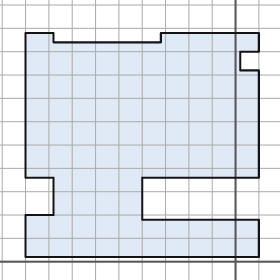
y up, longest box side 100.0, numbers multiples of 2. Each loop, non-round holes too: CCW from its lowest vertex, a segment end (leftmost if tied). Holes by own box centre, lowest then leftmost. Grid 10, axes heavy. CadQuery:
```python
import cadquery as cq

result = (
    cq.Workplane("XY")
    .moveTo(-90.0, 2.0)
    .lineTo(10.0, 2.0)
    .lineTo(10.0, 18.0)
    .lineTo(-40.0, 18.0)
    .lineTo(-40.0, 36.0)
    .lineTo(10.0, 36.0)
    .lineTo(10.0, 82.0)
    .lineTo(2.0, 82.0)
    .lineTo(2.0, 90.0)
    .lineTo(10.0, 90.0)
    .lineTo(10.0, 98.0)
    .lineTo(-32.0, 98.0)
    .lineTo(-32.0, 94.0)
    .lineTo(-78.0, 94.0)
    .lineTo(-78.0, 98.0)
    .lineTo(-90.0, 98.0)
    .lineTo(-90.0, 36.0)
    .lineTo(-78.0, 36.0)
    .lineTo(-78.0, 20.0)
    .lineTo(-90.0, 20.0)
    .close()
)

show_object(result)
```